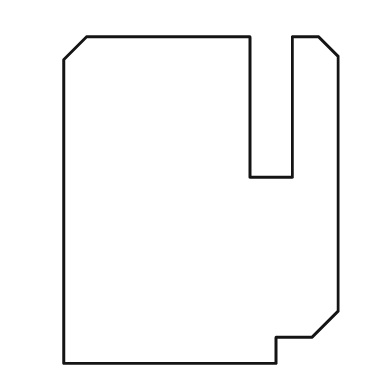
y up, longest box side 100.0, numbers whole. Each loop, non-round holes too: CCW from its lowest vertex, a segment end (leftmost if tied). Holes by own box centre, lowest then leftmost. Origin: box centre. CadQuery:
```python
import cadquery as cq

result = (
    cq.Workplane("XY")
    .moveTo(-42.0, -50.0)
    .lineTo(23.0, -50.0)
    .lineTo(23.0, -42.0)
    .lineTo(34.0, -42.0)
    .lineTo(42.0, -34.0)
    .lineTo(42.0, 44.0)
    .lineTo(36.0, 50.0)
    .lineTo(28.0, 50.0)
    .lineTo(28.0, 7.0)
    .lineTo(15.0, 7.0)
    .lineTo(15.0, 50.0)
    .lineTo(-35.0, 50.0)
    .lineTo(-42.0, 43.0)
    .close()
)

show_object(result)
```